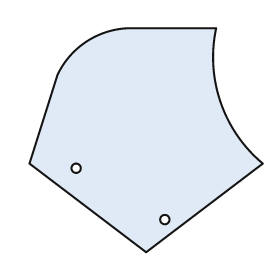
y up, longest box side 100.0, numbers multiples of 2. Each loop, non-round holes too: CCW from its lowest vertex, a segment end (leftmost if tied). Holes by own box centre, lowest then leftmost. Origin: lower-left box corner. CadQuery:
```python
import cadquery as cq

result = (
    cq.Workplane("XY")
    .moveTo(50.0, 0.0)
    .lineTo(100.0, 38.0)
    .threePointArc((82.0, 64.0), (80.0, 96.0))
    .lineTo(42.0, 96.0)
    .threePointArc((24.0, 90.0), (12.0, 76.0))
    .lineTo(0.0, 38.0)
    .close()
    .moveTo(58.0, 14.0)
    .circle(2.0)
    .moveTo(20.0, 36.0)
    .circle(2.0)
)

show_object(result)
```